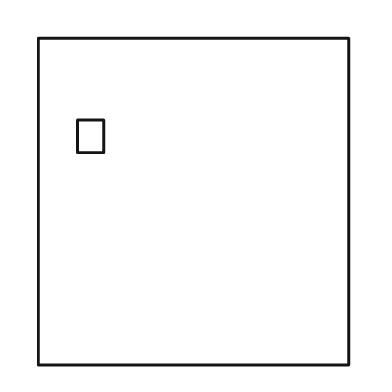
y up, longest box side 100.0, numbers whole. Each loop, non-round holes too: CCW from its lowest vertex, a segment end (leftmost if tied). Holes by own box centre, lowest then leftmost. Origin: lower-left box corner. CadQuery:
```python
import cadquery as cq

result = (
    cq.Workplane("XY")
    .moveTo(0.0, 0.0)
    .lineTo(95.0, 0.0)
    .lineTo(95.0, 100.0)
    .lineTo(0.0, 100.0)
    .close()
    .moveTo(12.0, 65.0)
    .lineTo(20.0, 65.0)
    .lineTo(20.0, 75.0)
    .lineTo(12.0, 75.0)
    .close()
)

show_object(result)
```